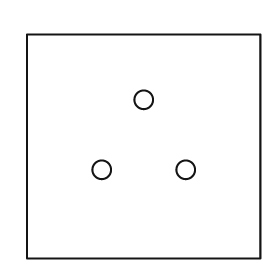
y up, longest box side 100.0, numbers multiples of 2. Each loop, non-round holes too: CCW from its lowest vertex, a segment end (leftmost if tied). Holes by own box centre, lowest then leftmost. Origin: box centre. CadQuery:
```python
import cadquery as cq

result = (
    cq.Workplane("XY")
    .moveTo(-50.0, -48.0)
    .lineTo(50.0, -48.0)
    .lineTo(50.0, 48.0)
    .lineTo(-50.0, 48.0)
    .close()
    .moveTo(-18.0, -10.0)
    .circle(4.0)
    .moveTo(18.0, -10.0)
    .circle(4.0)
    .moveTo(0.0, 20.0)
    .circle(4.0)
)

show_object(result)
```